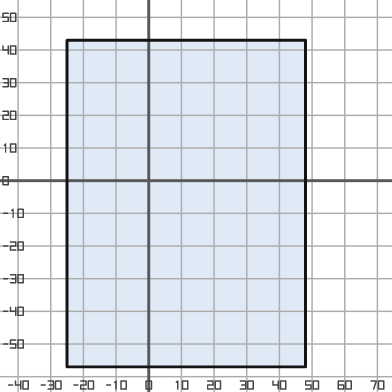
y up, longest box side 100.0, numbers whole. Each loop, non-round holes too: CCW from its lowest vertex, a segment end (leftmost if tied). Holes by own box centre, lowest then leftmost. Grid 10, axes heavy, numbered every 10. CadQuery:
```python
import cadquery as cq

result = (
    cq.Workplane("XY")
    .moveTo(-25.0, -57.0)
    .lineTo(48.0, -57.0)
    .lineTo(48.0, 43.0)
    .lineTo(-25.0, 43.0)
    .close()
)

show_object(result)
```